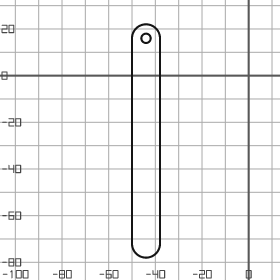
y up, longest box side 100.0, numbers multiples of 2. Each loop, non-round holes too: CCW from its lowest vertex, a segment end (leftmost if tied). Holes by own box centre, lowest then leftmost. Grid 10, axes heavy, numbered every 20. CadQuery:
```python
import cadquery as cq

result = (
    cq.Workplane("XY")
    .moveTo(-50.0, -72.0)
    .threePointArc((-44.0, -78.0), (-38.0, -72.0))
    .lineTo(-38.0, 16.0)
    .threePointArc((-44.0, 22.0), (-50.0, 16.0))
    .close()
    .moveTo(-44.0, 16.0)
    .circle(2.0)
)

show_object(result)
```